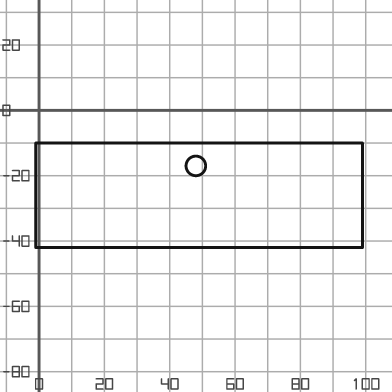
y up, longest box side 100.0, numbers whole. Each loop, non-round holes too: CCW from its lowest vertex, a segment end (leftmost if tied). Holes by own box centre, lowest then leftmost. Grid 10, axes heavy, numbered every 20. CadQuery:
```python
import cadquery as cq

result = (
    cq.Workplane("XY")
    .moveTo(-1.0, -42.0)
    .lineTo(99.0, -42.0)
    .lineTo(99.0, -10.0)
    .lineTo(-1.0, -10.0)
    .close()
    .moveTo(48.0, -17.0)
    .circle(3.0)
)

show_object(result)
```